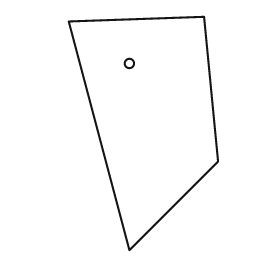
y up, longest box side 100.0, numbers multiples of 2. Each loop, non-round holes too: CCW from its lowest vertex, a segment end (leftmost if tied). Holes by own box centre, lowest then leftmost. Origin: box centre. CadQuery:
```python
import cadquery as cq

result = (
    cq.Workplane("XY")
    .moveTo(-6.0, -50.0)
    .lineTo(32.0, -12.0)
    .lineTo(26.0, 50.0)
    .lineTo(-32.0, 48.0)
    .close()
    .moveTo(-6.0, 30.0)
    .circle(2.0)
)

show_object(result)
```